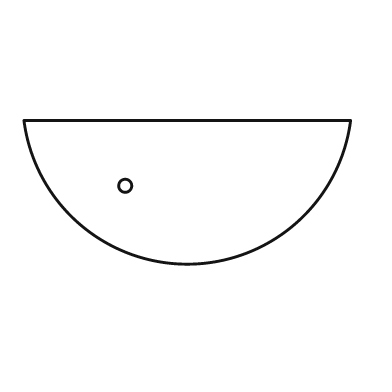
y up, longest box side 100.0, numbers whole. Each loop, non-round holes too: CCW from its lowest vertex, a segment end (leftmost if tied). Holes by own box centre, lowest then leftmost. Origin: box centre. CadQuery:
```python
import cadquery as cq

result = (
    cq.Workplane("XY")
    .moveTo(-50.0, 22.0)
    .threePointArc((0.0, -22.0), (50.0, 22.0))
    .close()
    .moveTo(-19.0, 2.0)
    .circle(2.0)
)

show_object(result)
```